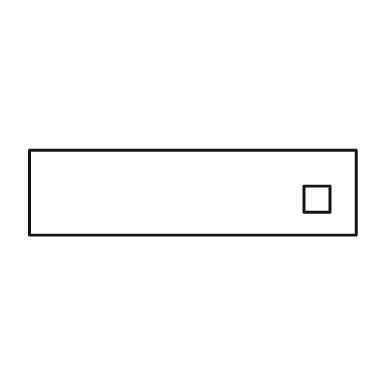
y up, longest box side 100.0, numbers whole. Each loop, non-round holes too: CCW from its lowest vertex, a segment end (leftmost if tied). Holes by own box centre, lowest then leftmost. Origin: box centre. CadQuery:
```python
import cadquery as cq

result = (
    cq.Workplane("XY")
    .moveTo(-50.0, -13.0)
    .lineTo(50.0, -13.0)
    .lineTo(50.0, 13.0)
    .lineTo(-50.0, 13.0)
    .close()
    .moveTo(34.0, -6.0)
    .lineTo(42.0, -6.0)
    .lineTo(42.0, 2.0)
    .lineTo(34.0, 2.0)
    .close()
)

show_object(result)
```